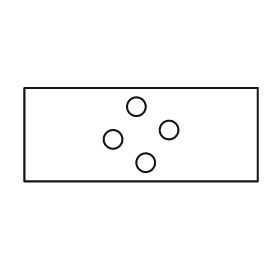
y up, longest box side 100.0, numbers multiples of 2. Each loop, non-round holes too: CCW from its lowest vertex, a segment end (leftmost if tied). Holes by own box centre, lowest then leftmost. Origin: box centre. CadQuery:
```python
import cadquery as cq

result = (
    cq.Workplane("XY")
    .moveTo(-50.0, -20.0)
    .lineTo(50.0, -20.0)
    .lineTo(50.0, 20.0)
    .lineTo(-50.0, 20.0)
    .close()
    .moveTo(2.0, -12.0)
    .circle(4.0)
    .moveTo(-12.0, -2.0)
    .circle(4.0)
    .moveTo(12.0, 2.0)
    .circle(4.0)
    .moveTo(-2.0, 12.0)
    .circle(4.0)
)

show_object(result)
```